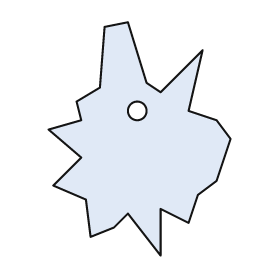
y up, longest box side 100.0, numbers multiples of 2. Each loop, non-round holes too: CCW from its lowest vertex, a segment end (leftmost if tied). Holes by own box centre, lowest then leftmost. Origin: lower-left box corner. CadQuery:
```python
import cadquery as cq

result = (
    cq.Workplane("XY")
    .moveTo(48.0, 0.0)
    .lineTo(48.0, 20.0)
    .lineTo(60.0, 14.0)
    .lineTo(64.0, 26.0)
    .lineTo(72.0, 32.0)
    .lineTo(78.0, 50.0)
    .lineTo(72.0, 58.0)
    .lineTo(60.0, 62.0)
    .lineTo(66.0, 88.0)
    .lineTo(48.0, 70.0)
    .lineTo(42.0, 74.0)
    .lineTo(34.0, 100.0)
    .lineTo(24.0, 98.0)
    .lineTo(22.0, 72.0)
    .lineTo(12.0, 66.0)
    .lineTo(14.0, 58.0)
    .lineTo(0.0, 54.0)
    .lineTo(14.0, 42.0)
    .lineTo(2.0, 30.0)
    .lineTo(16.0, 24.0)
    .lineTo(18.0, 8.0)
    .lineTo(28.0, 12.0)
    .lineTo(34.0, 18.0)
    .close()
    .moveTo(38.0, 62.0)
    .circle(4.0)
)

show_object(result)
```